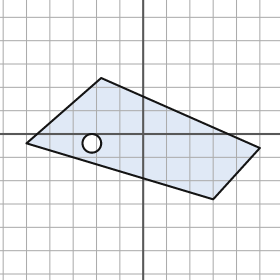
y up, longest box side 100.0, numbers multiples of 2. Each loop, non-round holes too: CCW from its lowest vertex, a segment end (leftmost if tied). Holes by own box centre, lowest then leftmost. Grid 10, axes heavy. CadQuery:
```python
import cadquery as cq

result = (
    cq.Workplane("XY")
    .moveTo(30.0, -28.0)
    .lineTo(50.0, -6.0)
    .lineTo(-18.0, 24.0)
    .lineTo(-50.0, -4.0)
    .close()
    .moveTo(-22.0, -4.0)
    .circle(4.0)
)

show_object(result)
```